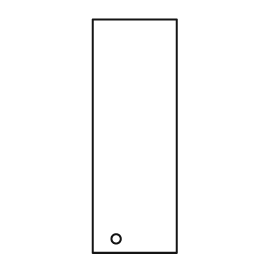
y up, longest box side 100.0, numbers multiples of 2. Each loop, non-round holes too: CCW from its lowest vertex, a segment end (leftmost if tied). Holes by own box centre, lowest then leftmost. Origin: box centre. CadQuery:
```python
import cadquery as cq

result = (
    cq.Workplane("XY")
    .moveTo(-18.0, -50.0)
    .lineTo(18.0, -50.0)
    .lineTo(18.0, 50.0)
    .lineTo(-18.0, 50.0)
    .close()
    .moveTo(-8.0, -44.0)
    .circle(2.0)
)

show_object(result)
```